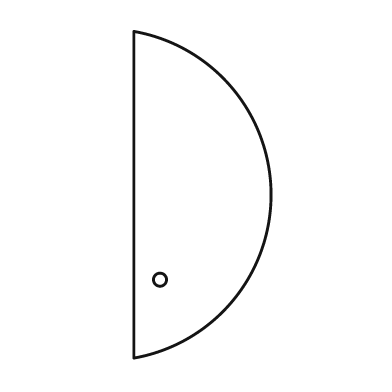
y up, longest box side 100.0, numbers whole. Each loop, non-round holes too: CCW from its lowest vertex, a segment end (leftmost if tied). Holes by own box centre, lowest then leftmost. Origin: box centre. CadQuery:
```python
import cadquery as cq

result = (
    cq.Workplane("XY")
    .moveTo(-21.0, -50.0)
    .threePointArc((21.0, 0.0), (-21.0, 50.0))
    .close()
    .moveTo(-13.0, -26.0)
    .circle(2.0)
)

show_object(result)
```